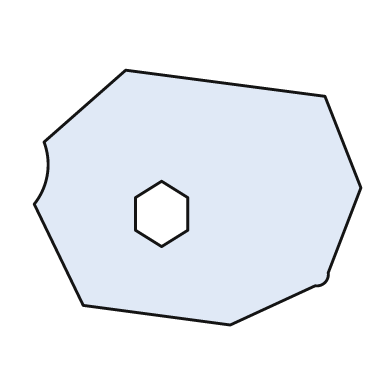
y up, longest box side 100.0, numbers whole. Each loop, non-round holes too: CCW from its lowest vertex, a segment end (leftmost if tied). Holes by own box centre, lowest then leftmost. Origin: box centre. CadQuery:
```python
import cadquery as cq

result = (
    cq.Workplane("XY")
    .moveTo(10.0, -39.0)
    .lineTo(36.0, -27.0)
    .threePointArc((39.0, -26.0), (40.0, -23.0))
    .lineTo(50.0, 3.0)
    .lineTo(39.0, 31.0)
    .lineTo(-22.0, 39.0)
    .lineTo(-47.0, 17.0)
    .threePointArc((-46.0, 7.0), (-50.0, -2.0))
    .lineTo(-35.0, -33.0)
    .close()
    .moveTo(-11.0, -15.0)
    .lineTo(-3.0, -10.0)
    .lineTo(-3.0, 0.0)
    .lineTo(-11.0, 5.0)
    .lineTo(-19.0, 0.0)
    .lineTo(-19.0, -10.0)
    .close()
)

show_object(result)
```